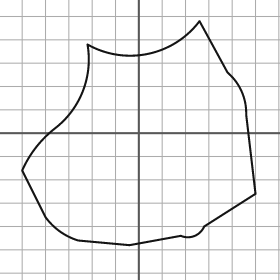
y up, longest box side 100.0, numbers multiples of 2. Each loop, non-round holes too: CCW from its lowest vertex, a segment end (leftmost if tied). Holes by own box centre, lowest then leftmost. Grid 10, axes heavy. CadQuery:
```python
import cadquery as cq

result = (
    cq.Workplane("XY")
    .moveTo(-4.0, -48.0)
    .lineTo(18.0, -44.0)
    .threePointArc((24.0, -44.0), (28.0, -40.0))
    .lineTo(50.0, -26.0)
    .lineTo(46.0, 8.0)
    .threePointArc((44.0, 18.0), (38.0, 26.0))
    .lineTo(26.0, 48.0)
    .threePointArc((4.0, 34.0), (-22.0, 38.0))
    .threePointArc((-24.0, 18.0), (-36.0, 2.0))
    .threePointArc((-44.0, -6.0), (-50.0, -16.0))
    .lineTo(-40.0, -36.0)
    .threePointArc((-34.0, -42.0), (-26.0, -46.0))
    .close()
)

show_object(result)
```